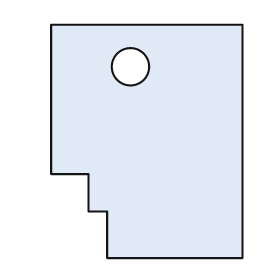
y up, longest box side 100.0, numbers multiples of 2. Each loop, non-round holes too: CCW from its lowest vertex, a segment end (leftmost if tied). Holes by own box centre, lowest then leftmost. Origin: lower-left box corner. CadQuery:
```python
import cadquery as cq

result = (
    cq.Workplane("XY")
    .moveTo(24.0, 0.0)
    .lineTo(82.0, 0.0)
    .lineTo(82.0, 100.0)
    .lineTo(0.0, 100.0)
    .lineTo(0.0, 36.0)
    .lineTo(16.0, 36.0)
    .lineTo(16.0, 20.0)
    .lineTo(24.0, 20.0)
    .close()
    .moveTo(34.0, 82.0)
    .circle(8.0)
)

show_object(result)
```